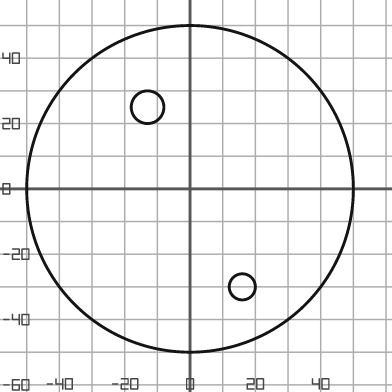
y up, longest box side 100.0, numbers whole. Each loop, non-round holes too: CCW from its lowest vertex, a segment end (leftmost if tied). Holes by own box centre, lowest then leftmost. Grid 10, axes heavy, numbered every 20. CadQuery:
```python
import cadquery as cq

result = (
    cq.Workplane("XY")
    .moveTo(0.0, 0.0)
    .circle(50.0)
    .moveTo(16.0, -30.0)
    .circle(4.0)
    .moveTo(-13.0, 25.0)
    .circle(5.0)
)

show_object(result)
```